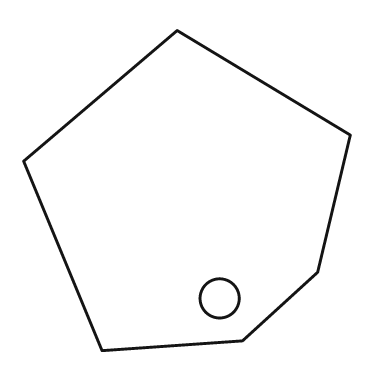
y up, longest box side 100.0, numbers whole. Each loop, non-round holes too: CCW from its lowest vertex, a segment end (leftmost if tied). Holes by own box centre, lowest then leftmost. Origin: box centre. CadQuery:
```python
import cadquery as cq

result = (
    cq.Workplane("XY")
    .moveTo(-26.0, -49.0)
    .lineTo(17.0, -46.0)
    .lineTo(40.0, -25.0)
    .lineTo(50.0, 17.0)
    .lineTo(-3.0, 49.0)
    .lineTo(-50.0, 9.0)
    .close()
    .moveTo(10.0, -33.0)
    .circle(6.0)
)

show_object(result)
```